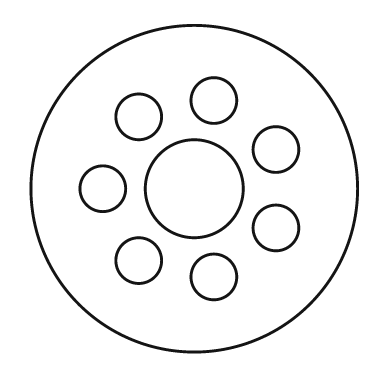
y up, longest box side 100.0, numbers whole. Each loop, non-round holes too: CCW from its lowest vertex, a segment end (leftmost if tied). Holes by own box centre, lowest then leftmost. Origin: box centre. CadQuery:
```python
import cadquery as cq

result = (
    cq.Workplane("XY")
    .moveTo(0.0, 0.0)
    .circle(50.0)
    .moveTo(6.0, -27.0)
    .circle(7.0)
    .moveTo(-17.0, -22.0)
    .circle(7.0)
    .moveTo(25.0, -12.0)
    .circle(7.0)
    .moveTo(-28.0, 0.0)
    .circle(7.0)
    .moveTo(0.0, 0.0)
    .circle(15.0)
    .moveTo(25.0, 12.0)
    .circle(7.0)
    .moveTo(-17.0, 22.0)
    .circle(7.0)
    .moveTo(6.0, 27.0)
    .circle(7.0)
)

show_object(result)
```